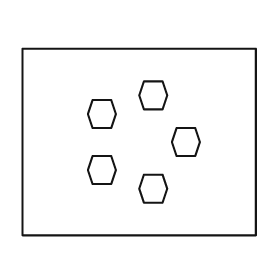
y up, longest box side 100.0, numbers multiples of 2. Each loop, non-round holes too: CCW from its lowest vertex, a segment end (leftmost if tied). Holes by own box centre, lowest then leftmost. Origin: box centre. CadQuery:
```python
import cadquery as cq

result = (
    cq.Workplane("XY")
    .moveTo(-50.0, -40.0)
    .lineTo(50.0, -40.0)
    .lineTo(50.0, 40.0)
    .lineTo(-50.0, 40.0)
    .close()
    .moveTo(2.0, -26.0)
    .lineTo(10.0, -26.0)
    .lineTo(12.0, -20.0)
    .lineTo(10.0, -14.0)
    .lineTo(2.0, -14.0)
    .lineTo(0.0, -20.0)
    .close()
    .moveTo(-20.0, -18.0)
    .lineTo(-12.0, -18.0)
    .lineTo(-10.0, -12.0)
    .lineTo(-12.0, -6.0)
    .lineTo(-20.0, -6.0)
    .lineTo(-22.0, -12.0)
    .close()
    .moveTo(16.0, -6.0)
    .lineTo(24.0, -6.0)
    .lineTo(26.0, 0.0)
    .lineTo(24.0, 6.0)
    .lineTo(16.0, 6.0)
    .lineTo(14.0, 0.0)
    .close()
    .moveTo(-20.0, 6.0)
    .lineTo(-12.0, 6.0)
    .lineTo(-10.0, 12.0)
    .lineTo(-12.0, 18.0)
    .lineTo(-20.0, 18.0)
    .lineTo(-22.0, 12.0)
    .close()
    .moveTo(2.0, 14.0)
    .lineTo(10.0, 14.0)
    .lineTo(12.0, 20.0)
    .lineTo(10.0, 26.0)
    .lineTo(2.0, 26.0)
    .lineTo(0.0, 20.0)
    .close()
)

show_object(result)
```